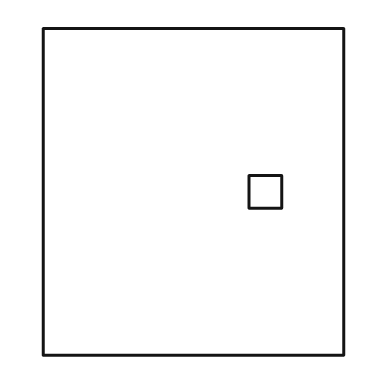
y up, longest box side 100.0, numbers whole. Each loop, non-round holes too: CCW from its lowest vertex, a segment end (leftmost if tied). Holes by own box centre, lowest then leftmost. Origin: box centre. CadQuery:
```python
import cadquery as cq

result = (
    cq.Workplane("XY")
    .moveTo(-46.0, -50.0)
    .lineTo(46.0, -50.0)
    .lineTo(46.0, 50.0)
    .lineTo(-46.0, 50.0)
    .close()
    .moveTo(17.0, -5.0)
    .lineTo(27.0, -5.0)
    .lineTo(27.0, 5.0)
    .lineTo(17.0, 5.0)
    .close()
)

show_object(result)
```